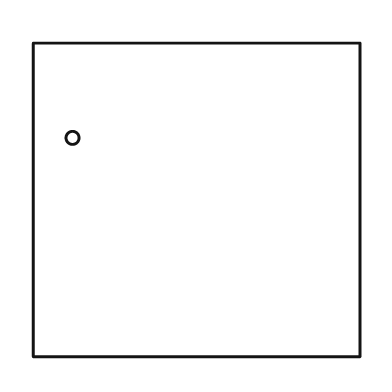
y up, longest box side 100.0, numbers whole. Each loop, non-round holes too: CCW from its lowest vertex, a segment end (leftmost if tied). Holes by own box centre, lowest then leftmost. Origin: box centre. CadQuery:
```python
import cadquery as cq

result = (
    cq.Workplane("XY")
    .moveTo(-50.0, -48.0)
    .lineTo(50.0, -48.0)
    .lineTo(50.0, 48.0)
    .lineTo(-50.0, 48.0)
    .close()
    .moveTo(-38.0, 19.0)
    .circle(2.0)
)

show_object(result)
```